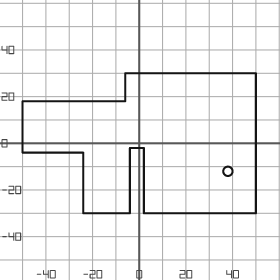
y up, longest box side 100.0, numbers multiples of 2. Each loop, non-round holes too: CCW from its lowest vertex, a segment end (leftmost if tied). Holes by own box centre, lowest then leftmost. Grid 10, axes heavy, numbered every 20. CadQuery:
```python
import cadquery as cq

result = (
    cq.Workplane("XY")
    .moveTo(-24.0, -30.0)
    .lineTo(-4.0, -30.0)
    .lineTo(-4.0, -2.0)
    .lineTo(2.0, -2.0)
    .lineTo(2.0, -30.0)
    .lineTo(50.0, -30.0)
    .lineTo(50.0, 30.0)
    .lineTo(-6.0, 30.0)
    .lineTo(-6.0, 18.0)
    .lineTo(-50.0, 18.0)
    .lineTo(-50.0, -4.0)
    .lineTo(-24.0, -4.0)
    .close()
    .moveTo(38.0, -12.0)
    .circle(2.0)
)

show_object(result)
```